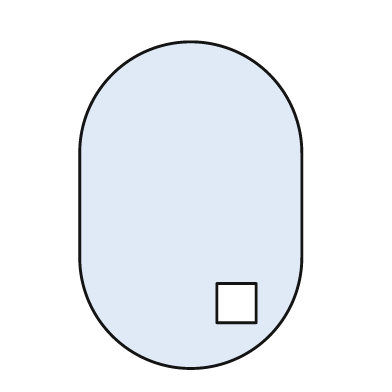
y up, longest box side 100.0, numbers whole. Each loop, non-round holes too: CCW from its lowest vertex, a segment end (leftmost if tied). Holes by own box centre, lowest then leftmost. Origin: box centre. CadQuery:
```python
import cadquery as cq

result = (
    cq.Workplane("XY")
    .moveTo(-34.0, -16.0)
    .threePointArc((0.0, -50.0), (34.0, -16.0))
    .lineTo(34.0, 16.0)
    .threePointArc((0.0, 50.0), (-34.0, 16.0))
    .close()
    .moveTo(8.0, -36.0)
    .lineTo(20.0, -36.0)
    .lineTo(20.0, -24.0)
    .lineTo(8.0, -24.0)
    .close()
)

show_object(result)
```